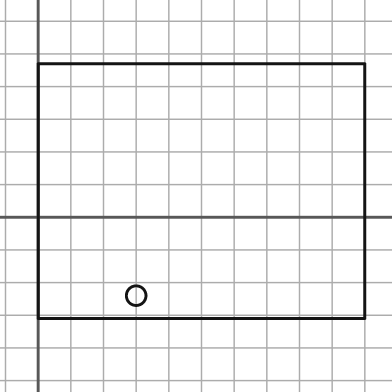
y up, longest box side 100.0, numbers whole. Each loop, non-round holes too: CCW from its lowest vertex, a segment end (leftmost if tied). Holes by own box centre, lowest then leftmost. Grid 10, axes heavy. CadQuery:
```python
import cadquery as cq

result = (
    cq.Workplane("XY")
    .moveTo(0.0, -31.0)
    .lineTo(100.0, -31.0)
    .lineTo(100.0, 47.0)
    .lineTo(0.0, 47.0)
    .close()
    .moveTo(30.0, -24.0)
    .circle(3.0)
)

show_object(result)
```